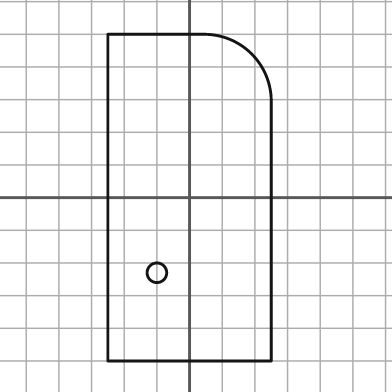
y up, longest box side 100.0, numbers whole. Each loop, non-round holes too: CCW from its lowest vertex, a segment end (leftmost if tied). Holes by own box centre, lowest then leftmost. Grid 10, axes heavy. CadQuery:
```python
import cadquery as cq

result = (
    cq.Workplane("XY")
    .moveTo(-25.0, -50.0)
    .lineTo(25.0, -50.0)
    .lineTo(25.0, 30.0)
    .threePointArc((19.0, 44.0), (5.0, 50.0))
    .lineTo(-25.0, 50.0)
    .close()
    .moveTo(-10.0, -23.0)
    .circle(3.0)
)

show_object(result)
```